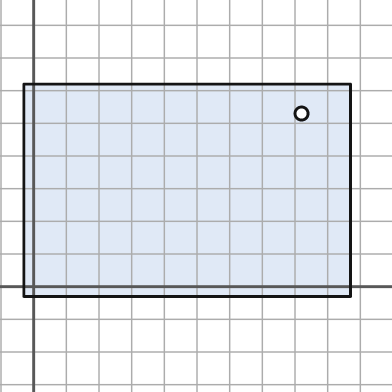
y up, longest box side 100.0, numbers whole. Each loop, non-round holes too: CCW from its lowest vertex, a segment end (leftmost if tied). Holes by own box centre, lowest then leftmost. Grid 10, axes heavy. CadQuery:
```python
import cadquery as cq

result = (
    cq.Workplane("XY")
    .moveTo(-3.0, -3.0)
    .lineTo(97.0, -3.0)
    .lineTo(97.0, 62.0)
    .lineTo(-3.0, 62.0)
    .close()
    .moveTo(82.0, 53.0)
    .circle(2.0)
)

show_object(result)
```